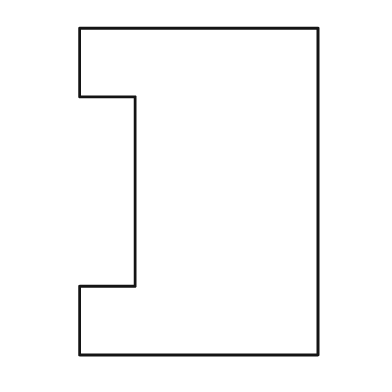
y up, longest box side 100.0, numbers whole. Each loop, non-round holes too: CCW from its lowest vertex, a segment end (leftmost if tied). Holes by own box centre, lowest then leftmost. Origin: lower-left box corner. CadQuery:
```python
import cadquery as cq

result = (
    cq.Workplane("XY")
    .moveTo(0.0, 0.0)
    .lineTo(73.0, 0.0)
    .lineTo(73.0, 100.0)
    .lineTo(0.0, 100.0)
    .lineTo(0.0, 79.0)
    .lineTo(17.0, 79.0)
    .lineTo(17.0, 21.0)
    .lineTo(0.0, 21.0)
    .close()
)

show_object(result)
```